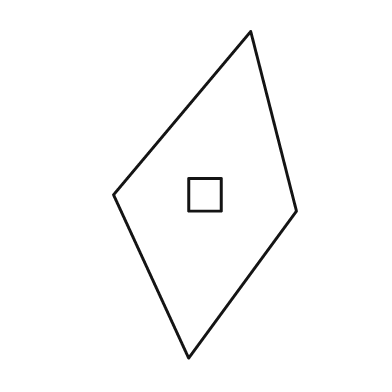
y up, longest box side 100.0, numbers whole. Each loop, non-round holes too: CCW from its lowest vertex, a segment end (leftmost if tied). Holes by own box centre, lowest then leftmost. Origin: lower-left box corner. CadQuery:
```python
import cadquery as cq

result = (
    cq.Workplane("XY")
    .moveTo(23.0, 0.0)
    .lineTo(56.0, 45.0)
    .lineTo(42.0, 100.0)
    .lineTo(0.0, 50.0)
    .close()
    .moveTo(23.0, 45.0)
    .lineTo(33.0, 45.0)
    .lineTo(33.0, 55.0)
    .lineTo(23.0, 55.0)
    .close()
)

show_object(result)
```